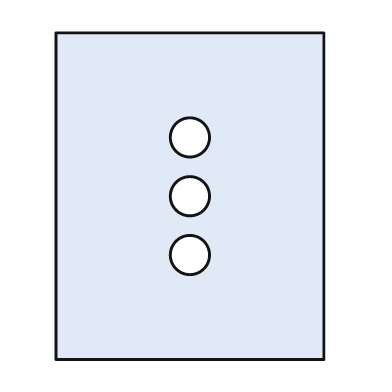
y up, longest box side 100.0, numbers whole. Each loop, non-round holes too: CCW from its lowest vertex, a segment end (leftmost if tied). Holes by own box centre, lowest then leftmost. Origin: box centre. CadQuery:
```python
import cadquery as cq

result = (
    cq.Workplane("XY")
    .moveTo(-41.0, -50.0)
    .lineTo(41.0, -50.0)
    .lineTo(41.0, 50.0)
    .lineTo(-41.0, 50.0)
    .close()
    .moveTo(0.0, -18.0)
    .circle(6.0)
    .moveTo(0.0, 0.0)
    .circle(6.0)
    .moveTo(0.0, 18.0)
    .circle(6.0)
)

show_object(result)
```